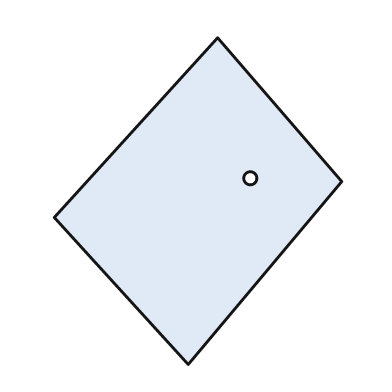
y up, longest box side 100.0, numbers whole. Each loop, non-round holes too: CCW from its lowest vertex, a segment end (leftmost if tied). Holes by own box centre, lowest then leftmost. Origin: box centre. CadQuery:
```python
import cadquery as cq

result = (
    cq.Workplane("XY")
    .moveTo(-3.0, -50.0)
    .lineTo(44.0, 6.0)
    .lineTo(6.0, 50.0)
    .lineTo(-44.0, -5.0)
    .close()
    .moveTo(16.0, 7.0)
    .circle(2.0)
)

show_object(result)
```